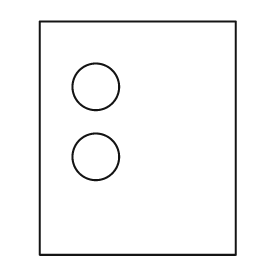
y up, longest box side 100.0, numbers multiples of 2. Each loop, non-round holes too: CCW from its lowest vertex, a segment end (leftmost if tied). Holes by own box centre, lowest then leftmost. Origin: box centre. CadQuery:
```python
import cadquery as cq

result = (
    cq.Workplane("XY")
    .moveTo(-42.0, -50.0)
    .lineTo(42.0, -50.0)
    .lineTo(42.0, 50.0)
    .lineTo(-42.0, 50.0)
    .close()
    .moveTo(-18.0, -8.0)
    .circle(10.0)
    .moveTo(-18.0, 22.0)
    .circle(10.0)
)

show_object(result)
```